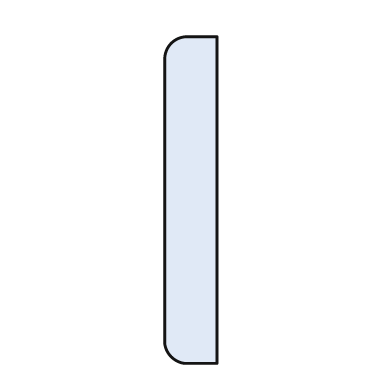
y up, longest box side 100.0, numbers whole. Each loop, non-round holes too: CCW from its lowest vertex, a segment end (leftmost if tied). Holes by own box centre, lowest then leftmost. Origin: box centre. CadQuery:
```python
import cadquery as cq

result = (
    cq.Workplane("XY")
    .moveTo(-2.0, -50.0)
    .lineTo(8.0, -50.0)
    .lineTo(8.0, 50.0)
    .lineTo(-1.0, 50.0)
    .threePointArc((-6.0, 48.0), (-8.0, 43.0))
    .lineTo(-8.0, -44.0)
    .threePointArc((-6.0, -48.0), (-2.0, -50.0))
    .close()
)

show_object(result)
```